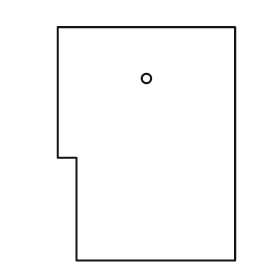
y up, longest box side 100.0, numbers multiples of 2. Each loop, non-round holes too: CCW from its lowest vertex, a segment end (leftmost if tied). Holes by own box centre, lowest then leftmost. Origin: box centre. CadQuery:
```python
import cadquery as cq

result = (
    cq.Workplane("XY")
    .moveTo(-30.0, -50.0)
    .lineTo(38.0, -50.0)
    .lineTo(38.0, 50.0)
    .lineTo(-38.0, 50.0)
    .lineTo(-38.0, -6.0)
    .lineTo(-30.0, -6.0)
    .close()
    .moveTo(0.0, 28.0)
    .circle(2.0)
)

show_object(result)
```